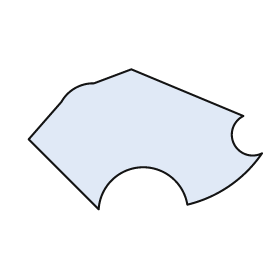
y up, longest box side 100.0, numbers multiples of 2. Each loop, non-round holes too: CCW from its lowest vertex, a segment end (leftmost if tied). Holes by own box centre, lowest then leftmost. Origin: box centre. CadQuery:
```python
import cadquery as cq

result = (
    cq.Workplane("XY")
    .moveTo(-20.0, -30.0)
    .threePointArc((-2.0, -12.0), (18.0, -28.0))
    .threePointArc((36.0, -20.0), (50.0, -6.0))
    .threePointArc((38.0, -2.0), (42.0, 10.0))
    .lineTo(-6.0, 30.0)
    .lineTo(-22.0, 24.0)
    .threePointArc((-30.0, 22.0), (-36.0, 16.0))
    .lineTo(-50.0, 0.0)
    .close()
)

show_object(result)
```